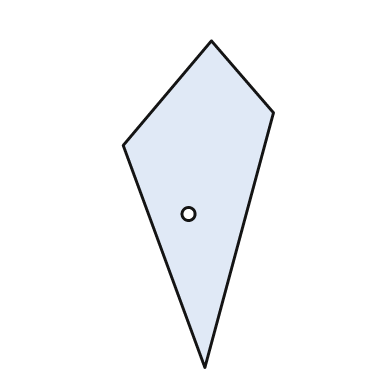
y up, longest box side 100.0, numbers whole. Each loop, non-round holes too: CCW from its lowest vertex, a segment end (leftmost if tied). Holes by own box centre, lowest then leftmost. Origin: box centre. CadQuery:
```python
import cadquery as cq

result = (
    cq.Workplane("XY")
    .moveTo(2.0, -50.0)
    .lineTo(23.0, 28.0)
    .lineTo(4.0, 50.0)
    .lineTo(-23.0, 18.0)
    .close()
    .moveTo(-3.0, -3.0)
    .circle(2.0)
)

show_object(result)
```